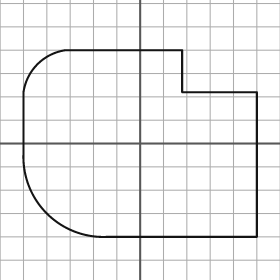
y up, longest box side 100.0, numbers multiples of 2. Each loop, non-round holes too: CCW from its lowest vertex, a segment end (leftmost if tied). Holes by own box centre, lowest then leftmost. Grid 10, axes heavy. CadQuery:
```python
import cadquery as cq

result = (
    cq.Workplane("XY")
    .moveTo(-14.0, -40.0)
    .lineTo(50.0, -40.0)
    .lineTo(50.0, 22.0)
    .lineTo(18.0, 22.0)
    .lineTo(18.0, 40.0)
    .lineTo(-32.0, 40.0)
    .threePointArc((-44.0, 34.0), (-50.0, 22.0))
    .lineTo(-50.0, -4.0)
    .threePointArc((-40.0, -30.0), (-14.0, -40.0))
    .close()
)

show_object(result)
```